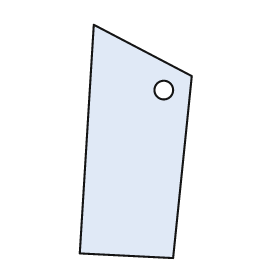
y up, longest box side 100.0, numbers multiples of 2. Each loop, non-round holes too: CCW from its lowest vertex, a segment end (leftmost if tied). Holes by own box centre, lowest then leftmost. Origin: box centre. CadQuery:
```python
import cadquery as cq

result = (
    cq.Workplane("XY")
    .moveTo(16.0, -50.0)
    .lineTo(24.0, 28.0)
    .lineTo(-18.0, 50.0)
    .lineTo(-24.0, -48.0)
    .close()
    .moveTo(12.0, 22.0)
    .circle(4.0)
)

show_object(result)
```